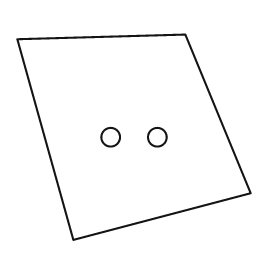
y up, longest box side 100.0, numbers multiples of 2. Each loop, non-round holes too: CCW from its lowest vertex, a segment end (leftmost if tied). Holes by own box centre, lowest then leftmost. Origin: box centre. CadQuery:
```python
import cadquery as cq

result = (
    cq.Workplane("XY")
    .moveTo(-26.0, -44.0)
    .lineTo(50.0, -24.0)
    .lineTo(22.0, 44.0)
    .lineTo(-50.0, 42.0)
    .close()
    .moveTo(-10.0, 0.0)
    .circle(4.0)
    .moveTo(10.0, 0.0)
    .circle(4.0)
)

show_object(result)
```